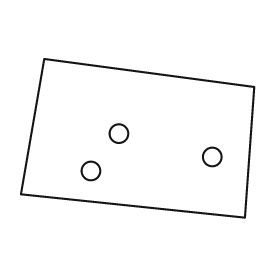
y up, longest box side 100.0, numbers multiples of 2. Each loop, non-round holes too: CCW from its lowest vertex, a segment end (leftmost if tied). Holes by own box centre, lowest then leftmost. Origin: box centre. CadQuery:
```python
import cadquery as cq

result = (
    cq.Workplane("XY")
    .moveTo(46.0, -34.0)
    .lineTo(50.0, 22.0)
    .lineTo(-40.0, 34.0)
    .lineTo(-50.0, -24.0)
    .close()
    .moveTo(-20.0, -14.0)
    .circle(4.0)
    .moveTo(32.0, -8.0)
    .circle(4.0)
    .moveTo(-8.0, 2.0)
    .circle(4.0)
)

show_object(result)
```